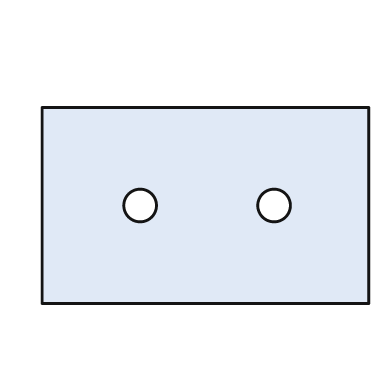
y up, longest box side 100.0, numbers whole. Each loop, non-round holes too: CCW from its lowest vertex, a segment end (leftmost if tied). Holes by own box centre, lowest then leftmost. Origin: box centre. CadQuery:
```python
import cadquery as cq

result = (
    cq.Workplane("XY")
    .moveTo(-50.0, -30.0)
    .lineTo(50.0, -30.0)
    .lineTo(50.0, 30.0)
    .lineTo(-50.0, 30.0)
    .close()
    .moveTo(-20.0, 0.0)
    .circle(5.0)
    .moveTo(21.0, 0.0)
    .circle(5.0)
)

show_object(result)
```